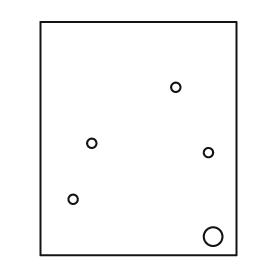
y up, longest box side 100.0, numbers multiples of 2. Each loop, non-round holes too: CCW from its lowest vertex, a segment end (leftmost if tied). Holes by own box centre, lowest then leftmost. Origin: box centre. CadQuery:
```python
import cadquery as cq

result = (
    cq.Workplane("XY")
    .moveTo(-42.0, -50.0)
    .lineTo(42.0, -50.0)
    .lineTo(42.0, 50.0)
    .lineTo(-42.0, 50.0)
    .close()
    .moveTo(32.0, -42.0)
    .circle(4.0)
    .moveTo(-28.0, -26.0)
    .circle(2.0)
    .moveTo(30.0, -6.0)
    .circle(2.0)
    .moveTo(-20.0, -2.0)
    .circle(2.0)
    .moveTo(16.0, 22.0)
    .circle(2.0)
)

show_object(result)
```